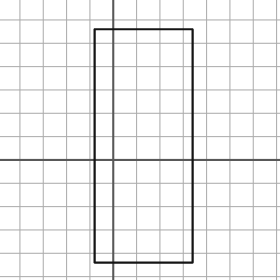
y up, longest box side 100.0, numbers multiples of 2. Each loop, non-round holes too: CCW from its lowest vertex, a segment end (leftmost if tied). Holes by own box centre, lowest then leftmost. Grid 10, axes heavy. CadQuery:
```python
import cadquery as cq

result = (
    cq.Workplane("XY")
    .moveTo(-8.0, -44.0)
    .lineTo(34.0, -44.0)
    .lineTo(34.0, 56.0)
    .lineTo(-8.0, 56.0)
    .close()
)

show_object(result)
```